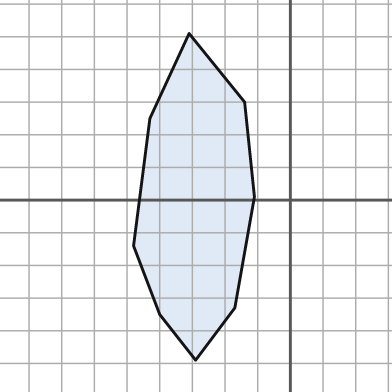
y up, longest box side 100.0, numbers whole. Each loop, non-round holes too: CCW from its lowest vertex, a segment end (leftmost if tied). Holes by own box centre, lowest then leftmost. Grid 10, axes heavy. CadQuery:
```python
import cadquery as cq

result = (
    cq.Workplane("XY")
    .moveTo(-29.0, -49.0)
    .lineTo(-17.0, -33.0)
    .lineTo(-11.0, 1.0)
    .lineTo(-14.0, 30.0)
    .lineTo(-31.0, 51.0)
    .lineTo(-43.0, 25.0)
    .lineTo(-48.0, -14.0)
    .lineTo(-40.0, -35.0)
    .close()
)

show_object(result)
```